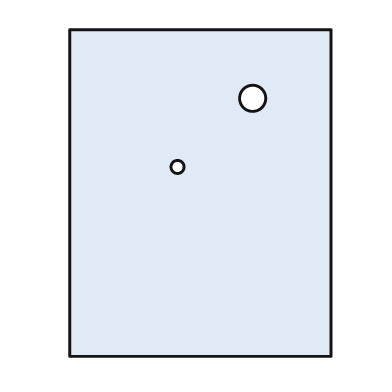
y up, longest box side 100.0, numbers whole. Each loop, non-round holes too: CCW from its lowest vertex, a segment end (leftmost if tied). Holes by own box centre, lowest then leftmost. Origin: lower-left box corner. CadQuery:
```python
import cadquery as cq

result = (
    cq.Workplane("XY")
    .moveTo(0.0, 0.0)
    .lineTo(80.0, 0.0)
    .lineTo(80.0, 100.0)
    .lineTo(0.0, 100.0)
    .close()
    .moveTo(33.0, 58.0)
    .circle(2.0)
    .moveTo(56.0, 79.0)
    .circle(4.0)
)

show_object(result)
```